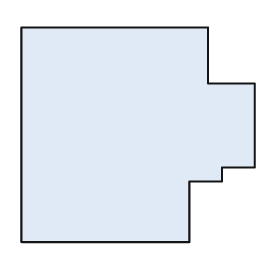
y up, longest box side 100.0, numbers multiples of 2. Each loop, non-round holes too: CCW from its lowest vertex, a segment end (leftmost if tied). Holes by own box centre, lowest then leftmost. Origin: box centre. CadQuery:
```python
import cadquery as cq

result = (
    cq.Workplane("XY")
    .moveTo(-50.0, -46.0)
    .lineTo(22.0, -46.0)
    .lineTo(22.0, -20.0)
    .lineTo(36.0, -20.0)
    .lineTo(36.0, -14.0)
    .lineTo(50.0, -14.0)
    .lineTo(50.0, 22.0)
    .lineTo(30.0, 22.0)
    .lineTo(30.0, 46.0)
    .lineTo(-50.0, 46.0)
    .close()
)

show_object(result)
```